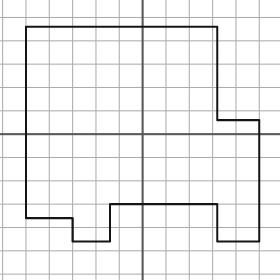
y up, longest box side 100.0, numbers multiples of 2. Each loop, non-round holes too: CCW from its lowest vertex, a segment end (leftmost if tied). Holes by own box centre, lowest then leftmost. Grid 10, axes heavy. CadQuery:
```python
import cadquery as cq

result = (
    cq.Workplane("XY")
    .moveTo(-30.0, -46.0)
    .lineTo(-14.0, -46.0)
    .lineTo(-14.0, -30.0)
    .lineTo(32.0, -30.0)
    .lineTo(32.0, -46.0)
    .lineTo(50.0, -46.0)
    .lineTo(50.0, 6.0)
    .lineTo(32.0, 6.0)
    .lineTo(32.0, 46.0)
    .lineTo(-50.0, 46.0)
    .lineTo(-50.0, -36.0)
    .lineTo(-30.0, -36.0)
    .close()
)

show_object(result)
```